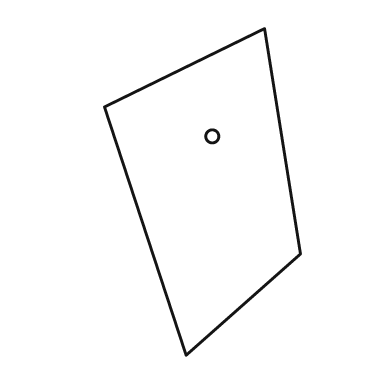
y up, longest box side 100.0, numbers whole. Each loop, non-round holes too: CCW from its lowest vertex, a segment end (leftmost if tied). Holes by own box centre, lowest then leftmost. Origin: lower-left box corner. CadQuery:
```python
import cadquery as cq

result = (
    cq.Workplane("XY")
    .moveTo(25.0, 0.0)
    .lineTo(60.0, 31.0)
    .lineTo(49.0, 100.0)
    .lineTo(0.0, 76.0)
    .close()
    .moveTo(33.0, 67.0)
    .circle(2.0)
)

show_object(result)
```